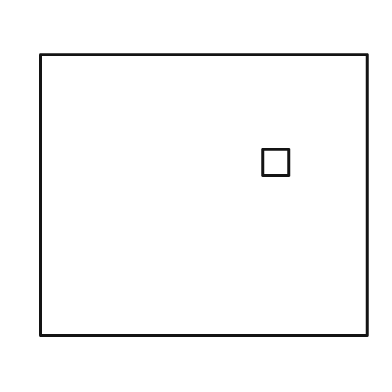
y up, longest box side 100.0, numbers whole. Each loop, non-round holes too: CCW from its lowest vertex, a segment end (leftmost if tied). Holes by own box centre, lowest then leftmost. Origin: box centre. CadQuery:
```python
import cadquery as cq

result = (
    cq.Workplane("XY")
    .moveTo(-50.0, -43.0)
    .lineTo(50.0, -43.0)
    .lineTo(50.0, 43.0)
    .lineTo(-50.0, 43.0)
    .close()
    .moveTo(18.0, 6.0)
    .lineTo(26.0, 6.0)
    .lineTo(26.0, 14.0)
    .lineTo(18.0, 14.0)
    .close()
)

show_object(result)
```